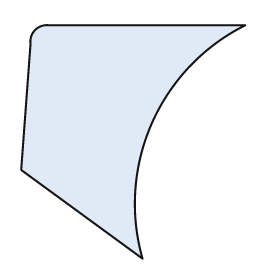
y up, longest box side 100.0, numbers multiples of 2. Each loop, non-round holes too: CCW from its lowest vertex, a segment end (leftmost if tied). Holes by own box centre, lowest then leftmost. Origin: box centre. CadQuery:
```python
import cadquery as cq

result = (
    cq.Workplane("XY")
    .moveTo(4.0, -50.0)
    .threePointArc((8.0, 8.0), (48.0, 50.0))
    .lineTo(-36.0, 50.0)
    .threePointArc((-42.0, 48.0), (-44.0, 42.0))
    .lineTo(-48.0, -12.0)
    .close()
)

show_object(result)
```